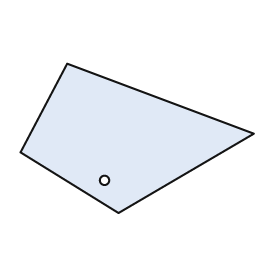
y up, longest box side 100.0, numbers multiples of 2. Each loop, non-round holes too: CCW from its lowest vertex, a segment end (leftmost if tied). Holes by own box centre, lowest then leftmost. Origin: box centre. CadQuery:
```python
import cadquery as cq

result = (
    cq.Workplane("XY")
    .moveTo(-8.0, -32.0)
    .lineTo(50.0, 2.0)
    .lineTo(-30.0, 32.0)
    .lineTo(-50.0, -6.0)
    .close()
    .moveTo(-14.0, -18.0)
    .circle(2.0)
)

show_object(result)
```